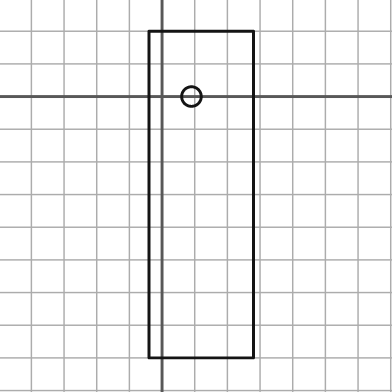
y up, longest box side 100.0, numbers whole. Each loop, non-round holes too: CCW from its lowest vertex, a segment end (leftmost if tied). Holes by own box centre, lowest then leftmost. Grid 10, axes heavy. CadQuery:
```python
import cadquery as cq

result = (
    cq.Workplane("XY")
    .moveTo(-4.0, -80.0)
    .lineTo(28.0, -80.0)
    .lineTo(28.0, 20.0)
    .lineTo(-4.0, 20.0)
    .close()
    .moveTo(9.0, 0.0)
    .circle(3.0)
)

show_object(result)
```